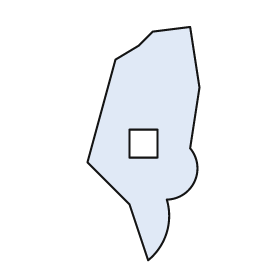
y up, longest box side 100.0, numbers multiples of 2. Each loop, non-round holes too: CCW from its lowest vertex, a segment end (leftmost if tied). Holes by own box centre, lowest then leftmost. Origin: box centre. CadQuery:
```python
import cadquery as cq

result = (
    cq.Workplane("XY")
    .moveTo(2.0, -50.0)
    .threePointArc((10.0, -38.0), (10.0, -24.0))
    .threePointArc((22.0, -16.0), (20.0, -2.0))
    .lineTo(24.0, 24.0)
    .lineTo(20.0, 50.0)
    .lineTo(4.0, 48.0)
    .lineTo(-2.0, 42.0)
    .lineTo(-12.0, 36.0)
    .lineTo(-24.0, -8.0)
    .lineTo(-6.0, -26.0)
    .close()
    .moveTo(-6.0, -6.0)
    .lineTo(6.0, -6.0)
    .lineTo(6.0, 6.0)
    .lineTo(-6.0, 6.0)
    .close()
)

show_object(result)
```